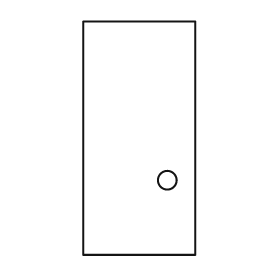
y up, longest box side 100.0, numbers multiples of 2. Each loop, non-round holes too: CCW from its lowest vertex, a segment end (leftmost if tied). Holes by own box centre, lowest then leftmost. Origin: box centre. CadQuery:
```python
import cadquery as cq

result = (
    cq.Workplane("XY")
    .moveTo(-24.0, -50.0)
    .lineTo(24.0, -50.0)
    .lineTo(24.0, 50.0)
    .lineTo(-24.0, 50.0)
    .close()
    .moveTo(12.0, -18.0)
    .circle(4.0)
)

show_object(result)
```